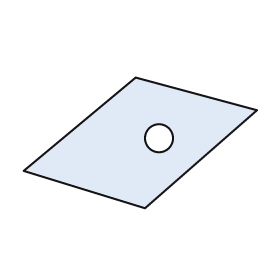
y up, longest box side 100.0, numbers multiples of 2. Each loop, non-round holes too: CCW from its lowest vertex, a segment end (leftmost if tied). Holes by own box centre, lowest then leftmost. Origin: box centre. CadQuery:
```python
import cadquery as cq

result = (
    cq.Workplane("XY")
    .moveTo(2.0, -28.0)
    .lineTo(50.0, 14.0)
    .lineTo(-2.0, 28.0)
    .lineTo(-50.0, -12.0)
    .close()
    .moveTo(8.0, 2.0)
    .circle(6.0)
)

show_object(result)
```